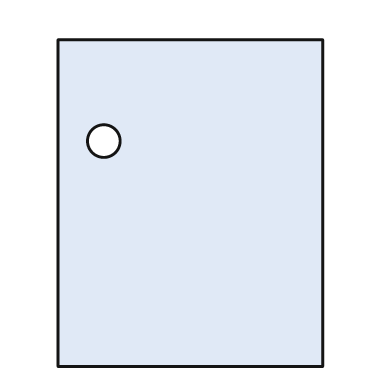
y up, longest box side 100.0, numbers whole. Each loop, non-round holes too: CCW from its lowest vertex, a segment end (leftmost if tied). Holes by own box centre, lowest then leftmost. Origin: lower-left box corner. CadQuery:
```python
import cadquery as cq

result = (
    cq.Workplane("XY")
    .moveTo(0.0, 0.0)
    .lineTo(81.0, 0.0)
    .lineTo(81.0, 100.0)
    .lineTo(0.0, 100.0)
    .close()
    .moveTo(14.0, 69.0)
    .circle(5.0)
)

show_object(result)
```